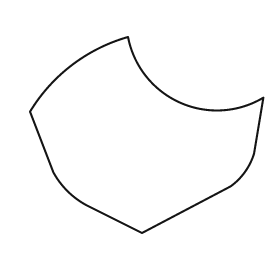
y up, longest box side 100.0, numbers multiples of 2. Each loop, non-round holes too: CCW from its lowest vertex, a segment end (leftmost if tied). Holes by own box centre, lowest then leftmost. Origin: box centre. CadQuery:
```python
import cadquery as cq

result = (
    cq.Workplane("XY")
    .moveTo(-2.0, -42.0)
    .lineTo(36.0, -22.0)
    .threePointArc((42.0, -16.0), (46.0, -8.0))
    .lineTo(50.0, 16.0)
    .threePointArc((14.0, 14.0), (-8.0, 42.0))
    .threePointArc((-32.0, 30.0), (-50.0, 10.0))
    .lineTo(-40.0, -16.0)
    .threePointArc((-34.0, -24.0), (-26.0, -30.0))
    .close()
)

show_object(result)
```